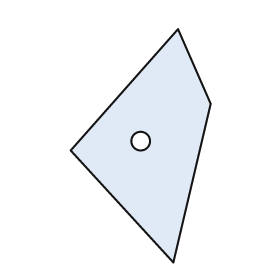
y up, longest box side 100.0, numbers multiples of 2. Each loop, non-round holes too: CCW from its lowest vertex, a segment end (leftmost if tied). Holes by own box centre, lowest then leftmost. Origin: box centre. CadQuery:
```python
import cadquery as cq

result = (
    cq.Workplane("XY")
    .moveTo(14.0, -50.0)
    .lineTo(30.0, 18.0)
    .lineTo(16.0, 50.0)
    .lineTo(-30.0, -2.0)
    .close()
    .moveTo(0.0, 2.0)
    .circle(4.0)
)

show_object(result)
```